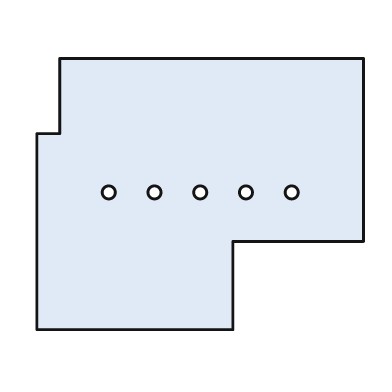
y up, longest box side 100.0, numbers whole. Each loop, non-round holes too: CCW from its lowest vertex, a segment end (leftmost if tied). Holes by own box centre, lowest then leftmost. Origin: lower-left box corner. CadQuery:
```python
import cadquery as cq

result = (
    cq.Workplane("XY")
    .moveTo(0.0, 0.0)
    .lineTo(60.0, 0.0)
    .lineTo(60.0, 27.0)
    .lineTo(100.0, 27.0)
    .lineTo(100.0, 83.0)
    .lineTo(7.0, 83.0)
    .lineTo(7.0, 60.0)
    .lineTo(0.0, 60.0)
    .close()
    .moveTo(22.0, 42.0)
    .circle(2.0)
    .moveTo(36.0, 42.0)
    .circle(2.0)
    .moveTo(50.0, 42.0)
    .circle(2.0)
    .moveTo(64.0, 42.0)
    .circle(2.0)
    .moveTo(78.0, 42.0)
    .circle(2.0)
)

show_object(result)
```